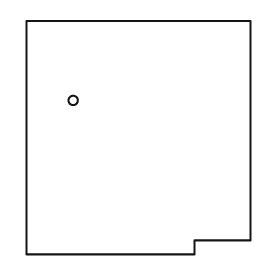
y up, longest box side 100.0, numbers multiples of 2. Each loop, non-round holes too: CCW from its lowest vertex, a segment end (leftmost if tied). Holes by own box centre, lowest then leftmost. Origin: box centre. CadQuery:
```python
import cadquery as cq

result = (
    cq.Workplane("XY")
    .moveTo(-48.0, -50.0)
    .lineTo(24.0, -50.0)
    .lineTo(24.0, -44.0)
    .lineTo(48.0, -44.0)
    .lineTo(48.0, 50.0)
    .lineTo(-48.0, 50.0)
    .close()
    .moveTo(-28.0, 16.0)
    .circle(2.0)
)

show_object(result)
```